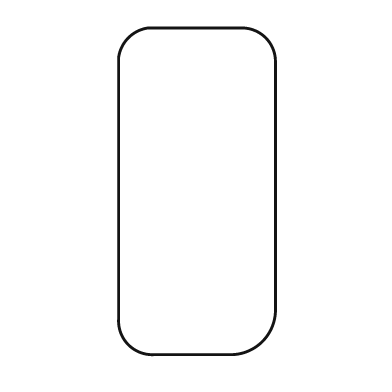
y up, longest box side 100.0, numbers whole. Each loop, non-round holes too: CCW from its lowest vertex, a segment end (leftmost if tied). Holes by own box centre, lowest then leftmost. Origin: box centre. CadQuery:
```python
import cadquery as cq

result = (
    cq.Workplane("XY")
    .moveTo(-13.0, -50.0)
    .lineTo(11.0, -50.0)
    .threePointArc((20.0, -46.0), (24.0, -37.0))
    .lineTo(24.0, 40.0)
    .threePointArc((21.0, 47.0), (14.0, 50.0))
    .lineTo(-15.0, 50.0)
    .threePointArc((-21.0, 47.0), (-24.0, 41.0))
    .lineTo(-24.0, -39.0)
    .threePointArc((-21.0, -47.0), (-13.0, -50.0))
    .close()
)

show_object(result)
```